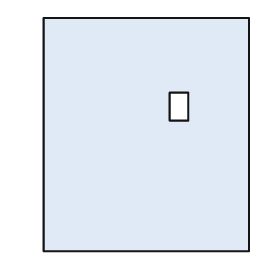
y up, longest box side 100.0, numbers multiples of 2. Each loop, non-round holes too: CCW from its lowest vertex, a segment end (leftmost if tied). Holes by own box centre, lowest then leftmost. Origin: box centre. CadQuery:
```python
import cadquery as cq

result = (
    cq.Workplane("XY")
    .moveTo(-44.0, -50.0)
    .lineTo(44.0, -50.0)
    .lineTo(44.0, 50.0)
    .lineTo(-44.0, 50.0)
    .close()
    .moveTo(10.0, 6.0)
    .lineTo(18.0, 6.0)
    .lineTo(18.0, 18.0)
    .lineTo(10.0, 18.0)
    .close()
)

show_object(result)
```